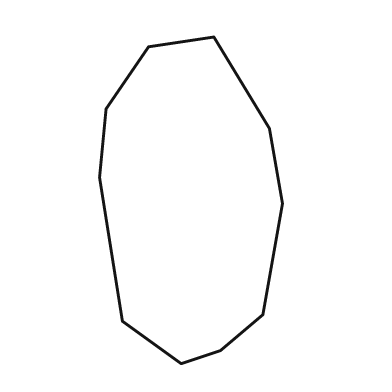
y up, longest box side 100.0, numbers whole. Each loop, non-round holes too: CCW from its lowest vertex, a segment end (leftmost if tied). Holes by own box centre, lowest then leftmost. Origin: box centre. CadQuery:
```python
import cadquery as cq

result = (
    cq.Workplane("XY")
    .moveTo(-3.0, -50.0)
    .lineTo(9.0, -46.0)
    .lineTo(22.0, -35.0)
    .lineTo(28.0, -1.0)
    .lineTo(24.0, 22.0)
    .lineTo(7.0, 50.0)
    .lineTo(-13.0, 47.0)
    .lineTo(-26.0, 28.0)
    .lineTo(-28.0, 7.0)
    .lineTo(-21.0, -37.0)
    .close()
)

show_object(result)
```